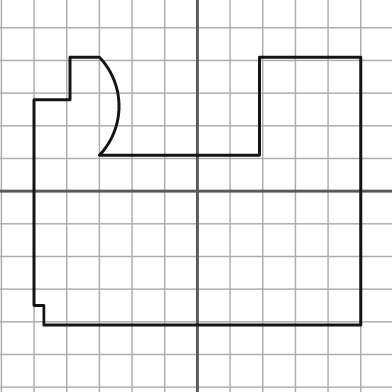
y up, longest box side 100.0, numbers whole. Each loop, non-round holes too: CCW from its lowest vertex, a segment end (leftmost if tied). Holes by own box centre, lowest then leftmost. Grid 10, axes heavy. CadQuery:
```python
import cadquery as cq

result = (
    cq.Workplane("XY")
    .moveTo(-47.0, -41.0)
    .lineTo(50.0, -41.0)
    .lineTo(50.0, 41.0)
    .lineTo(19.0, 41.0)
    .lineTo(19.0, 11.0)
    .lineTo(-30.0, 11.0)
    .threePointArc((-24.0, 26.0), (-30.0, 41.0))
    .lineTo(-39.0, 41.0)
    .lineTo(-39.0, 28.0)
    .lineTo(-50.0, 28.0)
    .lineTo(-50.0, -35.0)
    .lineTo(-47.0, -35.0)
    .close()
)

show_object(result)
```